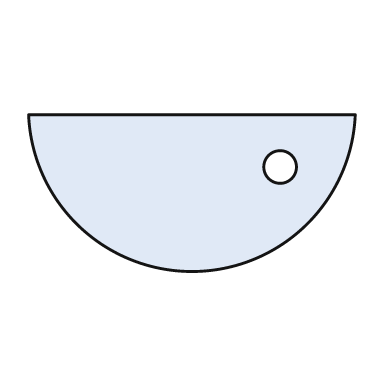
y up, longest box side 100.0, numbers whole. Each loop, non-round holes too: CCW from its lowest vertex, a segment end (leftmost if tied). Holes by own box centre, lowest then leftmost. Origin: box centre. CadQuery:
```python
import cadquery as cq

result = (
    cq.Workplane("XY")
    .moveTo(-50.0, 24.0)
    .threePointArc((0.0, -24.0), (50.0, 24.0))
    .close()
    .moveTo(27.0, 8.0)
    .circle(5.0)
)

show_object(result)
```